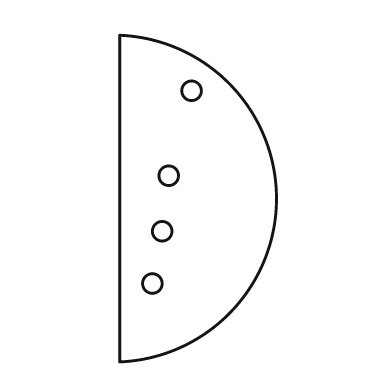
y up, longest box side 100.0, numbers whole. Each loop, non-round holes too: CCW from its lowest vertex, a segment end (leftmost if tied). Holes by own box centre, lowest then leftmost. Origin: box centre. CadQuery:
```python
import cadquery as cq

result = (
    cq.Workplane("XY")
    .moveTo(-24.0, -50.0)
    .threePointArc((24.0, 0.0), (-24.0, 50.0))
    .close()
    .moveTo(-14.0, -26.0)
    .circle(3.0)
    .moveTo(-11.0, -10.0)
    .circle(3.0)
    .moveTo(-9.0, 7.0)
    .circle(3.0)
    .moveTo(-2.0, 33.0)
    .circle(3.0)
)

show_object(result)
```